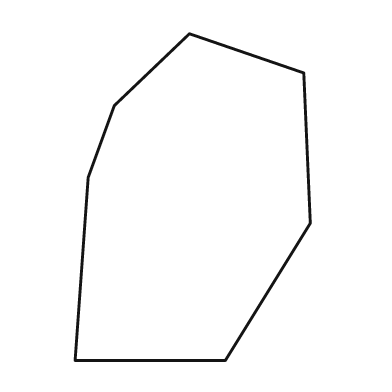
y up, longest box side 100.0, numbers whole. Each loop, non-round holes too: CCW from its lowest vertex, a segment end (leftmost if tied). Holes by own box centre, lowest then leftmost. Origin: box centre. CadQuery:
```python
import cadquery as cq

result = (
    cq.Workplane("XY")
    .moveTo(-36.0, -50.0)
    .lineTo(10.0, -50.0)
    .lineTo(36.0, -8.0)
    .lineTo(34.0, 38.0)
    .lineTo(-1.0, 50.0)
    .lineTo(-24.0, 28.0)
    .lineTo(-32.0, 6.0)
    .close()
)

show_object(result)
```